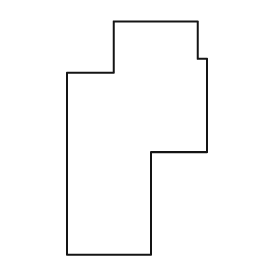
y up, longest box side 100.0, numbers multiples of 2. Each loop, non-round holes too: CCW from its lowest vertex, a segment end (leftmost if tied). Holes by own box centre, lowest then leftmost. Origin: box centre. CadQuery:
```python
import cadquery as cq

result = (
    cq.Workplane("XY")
    .moveTo(-30.0, -50.0)
    .lineTo(6.0, -50.0)
    .lineTo(6.0, -6.0)
    .lineTo(30.0, -6.0)
    .lineTo(30.0, 34.0)
    .lineTo(26.0, 34.0)
    .lineTo(26.0, 50.0)
    .lineTo(-10.0, 50.0)
    .lineTo(-10.0, 28.0)
    .lineTo(-30.0, 28.0)
    .close()
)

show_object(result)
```